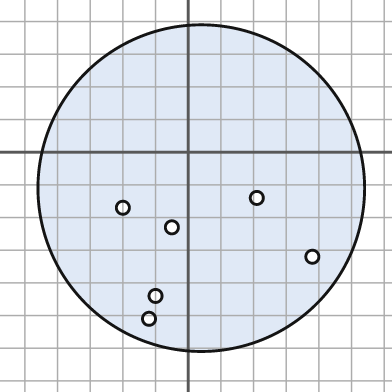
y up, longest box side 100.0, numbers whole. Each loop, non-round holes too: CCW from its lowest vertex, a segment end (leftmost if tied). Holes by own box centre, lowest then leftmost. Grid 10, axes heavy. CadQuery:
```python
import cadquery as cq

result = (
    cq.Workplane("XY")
    .moveTo(4.0, -11.0)
    .circle(50.0)
    .moveTo(-12.0, -51.0)
    .circle(2.0)
    .moveTo(-10.0, -44.0)
    .circle(2.0)
    .moveTo(38.0, -32.0)
    .circle(2.0)
    .moveTo(-5.0, -23.0)
    .circle(2.0)
    .moveTo(-20.0, -17.0)
    .circle(2.0)
    .moveTo(21.0, -14.0)
    .circle(2.0)
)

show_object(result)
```